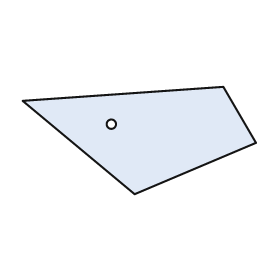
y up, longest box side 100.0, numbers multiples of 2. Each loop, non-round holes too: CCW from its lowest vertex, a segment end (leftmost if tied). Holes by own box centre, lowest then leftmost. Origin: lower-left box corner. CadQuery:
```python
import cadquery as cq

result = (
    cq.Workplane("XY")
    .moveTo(48.0, 0.0)
    .lineTo(100.0, 22.0)
    .lineTo(86.0, 46.0)
    .lineTo(0.0, 40.0)
    .close()
    .moveTo(38.0, 30.0)
    .circle(2.0)
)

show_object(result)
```